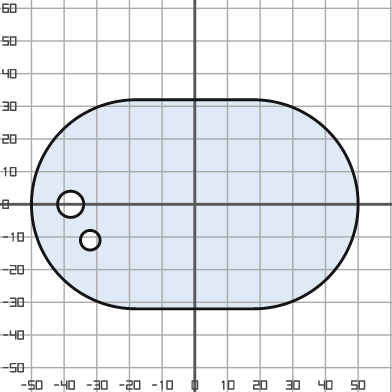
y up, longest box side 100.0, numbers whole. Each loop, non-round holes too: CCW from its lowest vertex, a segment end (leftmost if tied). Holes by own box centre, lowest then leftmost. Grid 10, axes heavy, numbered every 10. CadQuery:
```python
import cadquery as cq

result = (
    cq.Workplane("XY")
    .moveTo(-18.0, -32.0)
    .lineTo(18.0, -32.0)
    .threePointArc((50.0, 0.0), (18.0, 32.0))
    .lineTo(-18.0, 32.0)
    .threePointArc((-50.0, 0.0), (-18.0, -32.0))
    .close()
    .moveTo(-32.0, -11.0)
    .circle(3.0)
    .moveTo(-38.0, 0.0)
    .circle(4.0)
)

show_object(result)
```